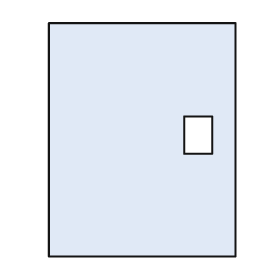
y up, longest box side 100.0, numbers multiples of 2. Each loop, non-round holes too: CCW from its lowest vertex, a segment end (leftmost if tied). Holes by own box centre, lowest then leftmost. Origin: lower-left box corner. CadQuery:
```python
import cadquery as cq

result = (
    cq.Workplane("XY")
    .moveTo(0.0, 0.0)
    .lineTo(80.0, 0.0)
    .lineTo(80.0, 100.0)
    .lineTo(0.0, 100.0)
    .close()
    .moveTo(58.0, 44.0)
    .lineTo(70.0, 44.0)
    .lineTo(70.0, 60.0)
    .lineTo(58.0, 60.0)
    .close()
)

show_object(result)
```